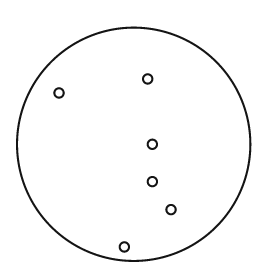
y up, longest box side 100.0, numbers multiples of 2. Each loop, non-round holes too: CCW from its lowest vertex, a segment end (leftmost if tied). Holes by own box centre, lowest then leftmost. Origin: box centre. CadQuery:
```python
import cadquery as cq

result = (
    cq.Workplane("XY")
    .moveTo(0.0, 0.0)
    .circle(50.0)
    .moveTo(-4.0, -44.0)
    .circle(2.0)
    .moveTo(16.0, -28.0)
    .circle(2.0)
    .moveTo(8.0, -16.0)
    .circle(2.0)
    .moveTo(8.0, 0.0)
    .circle(2.0)
    .moveTo(-32.0, 22.0)
    .circle(2.0)
    .moveTo(6.0, 28.0)
    .circle(2.0)
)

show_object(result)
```